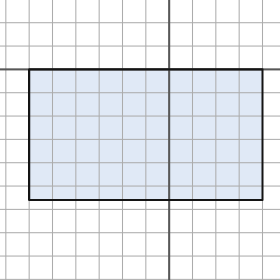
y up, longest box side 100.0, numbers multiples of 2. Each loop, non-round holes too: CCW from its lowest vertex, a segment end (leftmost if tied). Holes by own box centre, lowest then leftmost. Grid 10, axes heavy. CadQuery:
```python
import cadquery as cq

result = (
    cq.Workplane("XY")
    .moveTo(-60.0, -56.0)
    .lineTo(40.0, -56.0)
    .lineTo(40.0, 0.0)
    .lineTo(-60.0, 0.0)
    .close()
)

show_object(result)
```